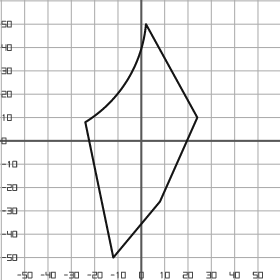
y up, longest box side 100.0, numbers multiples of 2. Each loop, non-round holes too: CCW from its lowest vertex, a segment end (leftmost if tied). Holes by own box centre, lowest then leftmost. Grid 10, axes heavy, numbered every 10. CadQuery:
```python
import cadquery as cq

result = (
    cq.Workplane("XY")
    .moveTo(-12.0, -50.0)
    .lineTo(8.0, -26.0)
    .lineTo(24.0, 10.0)
    .lineTo(2.0, 50.0)
    .threePointArc((-6.0, 26.0), (-24.0, 8.0))
    .close()
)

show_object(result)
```